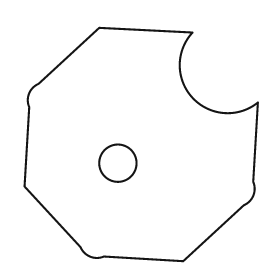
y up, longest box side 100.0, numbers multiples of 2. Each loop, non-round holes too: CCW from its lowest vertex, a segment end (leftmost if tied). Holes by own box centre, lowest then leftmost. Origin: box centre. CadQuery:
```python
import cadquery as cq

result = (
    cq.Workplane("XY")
    .moveTo(18.0, -50.0)
    .lineTo(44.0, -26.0)
    .threePointArc((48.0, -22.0), (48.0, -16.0))
    .lineTo(50.0, 18.0)
    .threePointArc((22.0, 20.0), (22.0, 48.0))
    .lineTo(-18.0, 50.0)
    .lineTo(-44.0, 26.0)
    .threePointArc((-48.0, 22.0), (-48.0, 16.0))
    .lineTo(-50.0, -18.0)
    .lineTo(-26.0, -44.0)
    .threePointArc((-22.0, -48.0), (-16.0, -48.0))
    .close()
    .moveTo(-10.0, -8.0)
    .circle(8.0)
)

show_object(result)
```